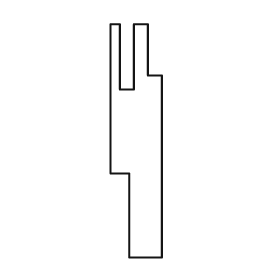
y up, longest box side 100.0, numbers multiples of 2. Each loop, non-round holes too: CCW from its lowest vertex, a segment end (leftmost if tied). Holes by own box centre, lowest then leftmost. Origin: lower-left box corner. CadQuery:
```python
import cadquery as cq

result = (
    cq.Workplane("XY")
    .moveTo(8.0, 0.0)
    .lineTo(22.0, 0.0)
    .lineTo(22.0, 78.0)
    .lineTo(16.0, 78.0)
    .lineTo(16.0, 100.0)
    .lineTo(10.0, 100.0)
    .lineTo(10.0, 72.0)
    .lineTo(4.0, 72.0)
    .lineTo(4.0, 100.0)
    .lineTo(0.0, 100.0)
    .lineTo(0.0, 36.0)
    .lineTo(8.0, 36.0)
    .close()
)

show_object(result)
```